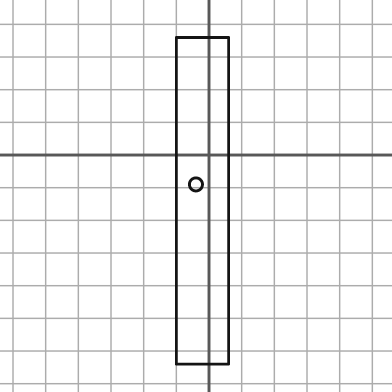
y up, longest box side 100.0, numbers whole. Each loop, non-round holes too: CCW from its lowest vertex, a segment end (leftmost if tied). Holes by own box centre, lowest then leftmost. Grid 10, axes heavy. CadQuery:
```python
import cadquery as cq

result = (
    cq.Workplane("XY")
    .moveTo(-10.0, -64.0)
    .lineTo(6.0, -64.0)
    .lineTo(6.0, 36.0)
    .lineTo(-10.0, 36.0)
    .close()
    .moveTo(-4.0, -9.0)
    .circle(2.0)
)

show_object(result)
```